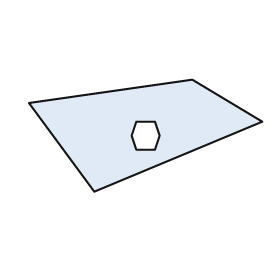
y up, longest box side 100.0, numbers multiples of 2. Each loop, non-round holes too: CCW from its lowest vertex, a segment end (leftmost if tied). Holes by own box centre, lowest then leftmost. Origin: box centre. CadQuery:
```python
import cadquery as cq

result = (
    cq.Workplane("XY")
    .moveTo(-22.0, -24.0)
    .lineTo(50.0, 6.0)
    .lineTo(20.0, 24.0)
    .lineTo(-50.0, 14.0)
    .close()
    .moveTo(-4.0, -6.0)
    .lineTo(4.0, -6.0)
    .lineTo(6.0, 0.0)
    .lineTo(4.0, 6.0)
    .lineTo(-4.0, 6.0)
    .lineTo(-6.0, 0.0)
    .close()
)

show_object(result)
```